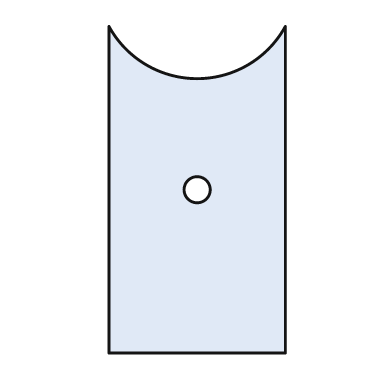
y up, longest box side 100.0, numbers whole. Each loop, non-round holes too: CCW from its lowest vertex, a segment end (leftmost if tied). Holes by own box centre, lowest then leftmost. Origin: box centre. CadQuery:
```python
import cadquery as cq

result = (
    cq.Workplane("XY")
    .moveTo(-27.0, -50.0)
    .lineTo(27.0, -50.0)
    .lineTo(27.0, 50.0)
    .threePointArc((0.0, 34.0), (-27.0, 50.0))
    .close()
    .moveTo(0.0, 0.0)
    .circle(4.0)
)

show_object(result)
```